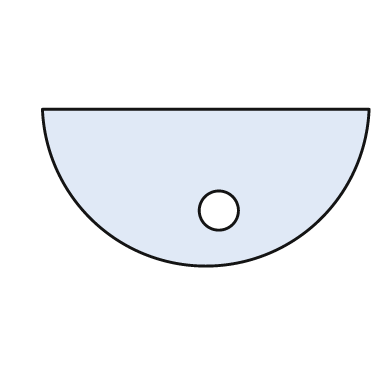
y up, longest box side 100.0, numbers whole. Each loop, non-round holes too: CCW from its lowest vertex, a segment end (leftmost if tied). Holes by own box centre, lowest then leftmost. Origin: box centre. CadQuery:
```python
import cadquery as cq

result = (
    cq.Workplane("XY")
    .moveTo(-50.0, 24.0)
    .threePointArc((0.0, -24.0), (50.0, 24.0))
    .close()
    .moveTo(4.0, -7.0)
    .circle(6.0)
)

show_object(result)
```